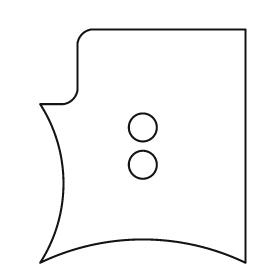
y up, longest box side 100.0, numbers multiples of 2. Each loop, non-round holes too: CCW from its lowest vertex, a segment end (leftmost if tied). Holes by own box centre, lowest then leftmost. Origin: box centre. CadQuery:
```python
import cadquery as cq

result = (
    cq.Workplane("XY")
    .moveTo(-44.0, -50.0)
    .threePointArc((0.0, -40.0), (44.0, -50.0))
    .lineTo(44.0, 50.0)
    .lineTo(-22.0, 50.0)
    .threePointArc((-26.0, 48.0), (-28.0, 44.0))
    .lineTo(-28.0, 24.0)
    .threePointArc((-30.0, 20.0), (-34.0, 18.0))
    .lineTo(-44.0, 18.0)
    .threePointArc((-34.0, -16.0), (-44.0, -50.0))
    .close()
    .moveTo(0.0, -8.0)
    .circle(6.0)
    .moveTo(0.0, 8.0)
    .circle(6.0)
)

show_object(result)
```